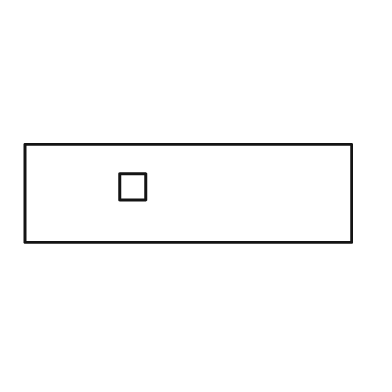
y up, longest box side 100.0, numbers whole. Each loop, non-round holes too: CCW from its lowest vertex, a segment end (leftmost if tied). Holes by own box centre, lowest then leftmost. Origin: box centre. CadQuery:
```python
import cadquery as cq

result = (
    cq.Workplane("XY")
    .moveTo(-50.0, -15.0)
    .lineTo(50.0, -15.0)
    .lineTo(50.0, 15.0)
    .lineTo(-50.0, 15.0)
    .close()
    .moveTo(-21.0, -2.0)
    .lineTo(-13.0, -2.0)
    .lineTo(-13.0, 6.0)
    .lineTo(-21.0, 6.0)
    .close()
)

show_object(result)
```